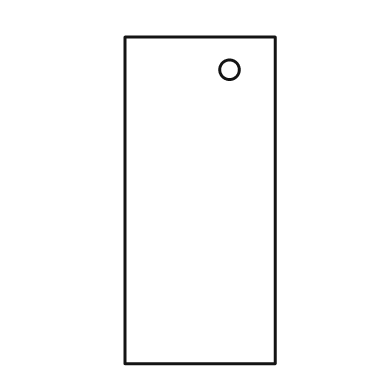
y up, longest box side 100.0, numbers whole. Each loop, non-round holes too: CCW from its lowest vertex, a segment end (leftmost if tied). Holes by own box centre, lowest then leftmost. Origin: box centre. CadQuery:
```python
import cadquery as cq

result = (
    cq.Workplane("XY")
    .moveTo(-23.0, -50.0)
    .lineTo(23.0, -50.0)
    .lineTo(23.0, 50.0)
    .lineTo(-23.0, 50.0)
    .close()
    .moveTo(9.0, 40.0)
    .circle(3.0)
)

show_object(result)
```